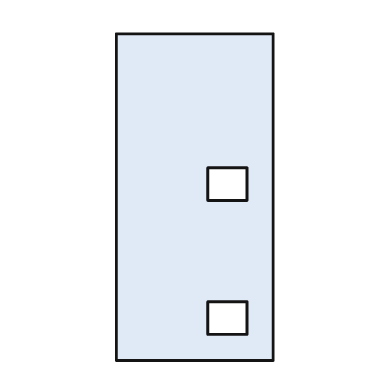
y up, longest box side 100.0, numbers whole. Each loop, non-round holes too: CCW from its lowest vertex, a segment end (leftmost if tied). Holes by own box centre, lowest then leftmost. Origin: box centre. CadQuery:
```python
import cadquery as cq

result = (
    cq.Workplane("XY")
    .moveTo(-24.0, -50.0)
    .lineTo(24.0, -50.0)
    .lineTo(24.0, 50.0)
    .lineTo(-24.0, 50.0)
    .close()
    .moveTo(4.0, -42.0)
    .lineTo(16.0, -42.0)
    .lineTo(16.0, -32.0)
    .lineTo(4.0, -32.0)
    .close()
    .moveTo(4.0, -1.0)
    .lineTo(16.0, -1.0)
    .lineTo(16.0, 9.0)
    .lineTo(4.0, 9.0)
    .close()
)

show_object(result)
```